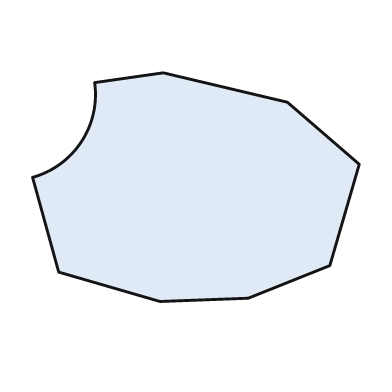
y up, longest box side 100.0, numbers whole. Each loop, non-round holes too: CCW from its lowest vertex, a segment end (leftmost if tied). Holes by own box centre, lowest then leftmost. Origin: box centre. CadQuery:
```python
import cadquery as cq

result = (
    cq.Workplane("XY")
    .moveTo(-11.0, -35.0)
    .lineTo(16.0, -34.0)
    .lineTo(41.0, -24.0)
    .lineTo(50.0, 7.0)
    .lineTo(28.0, 26.0)
    .lineTo(-10.0, 35.0)
    .lineTo(-31.0, 32.0)
    .threePointArc((-35.0, 14.0), (-50.0, 3.0))
    .lineTo(-42.0, -26.0)
    .close()
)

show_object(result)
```